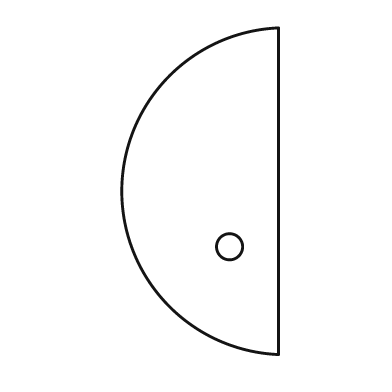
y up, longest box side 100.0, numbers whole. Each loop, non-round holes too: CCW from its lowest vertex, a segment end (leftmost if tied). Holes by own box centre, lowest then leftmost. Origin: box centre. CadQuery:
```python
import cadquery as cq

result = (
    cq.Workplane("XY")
    .moveTo(24.0, -50.0)
    .lineTo(24.0, 50.0)
    .threePointArc((-24.0, 0.0), (24.0, -50.0))
    .close()
    .moveTo(9.0, -17.0)
    .circle(4.0)
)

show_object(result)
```